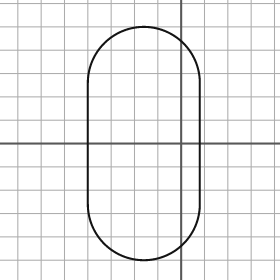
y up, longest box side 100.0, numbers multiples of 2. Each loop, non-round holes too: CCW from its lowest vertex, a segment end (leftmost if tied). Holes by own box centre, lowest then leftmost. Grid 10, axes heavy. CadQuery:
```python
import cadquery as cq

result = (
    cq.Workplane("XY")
    .moveTo(-40.0, -26.0)
    .threePointArc((-16.0, -50.0), (8.0, -26.0))
    .lineTo(8.0, 26.0)
    .threePointArc((-16.0, 50.0), (-40.0, 26.0))
    .close()
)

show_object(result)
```